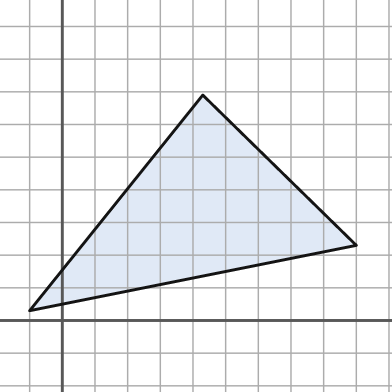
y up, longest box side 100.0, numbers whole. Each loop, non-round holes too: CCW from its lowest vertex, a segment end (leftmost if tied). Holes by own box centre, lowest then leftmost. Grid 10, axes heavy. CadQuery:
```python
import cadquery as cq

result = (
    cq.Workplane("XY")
    .moveTo(-10.0, 3.0)
    .lineTo(90.0, 23.0)
    .lineTo(43.0, 69.0)
    .close()
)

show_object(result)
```